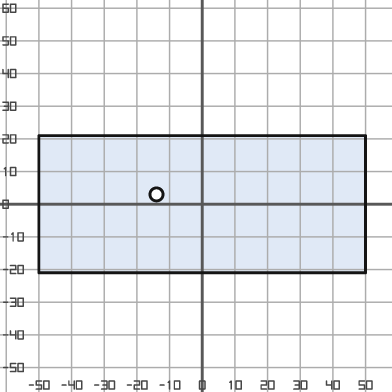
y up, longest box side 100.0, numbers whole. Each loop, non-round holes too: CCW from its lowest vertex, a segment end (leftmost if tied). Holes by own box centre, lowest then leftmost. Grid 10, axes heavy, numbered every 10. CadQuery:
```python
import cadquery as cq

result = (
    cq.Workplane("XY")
    .moveTo(-50.0, -21.0)
    .lineTo(50.0, -21.0)
    .lineTo(50.0, 21.0)
    .lineTo(-50.0, 21.0)
    .close()
    .moveTo(-14.0, 3.0)
    .circle(2.0)
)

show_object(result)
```